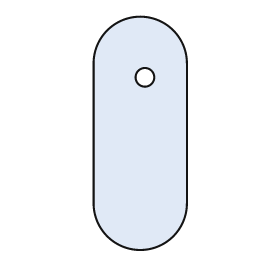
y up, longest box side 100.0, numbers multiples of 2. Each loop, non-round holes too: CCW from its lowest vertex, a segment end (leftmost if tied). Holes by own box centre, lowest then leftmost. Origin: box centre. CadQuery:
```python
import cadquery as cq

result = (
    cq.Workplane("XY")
    .moveTo(-20.0, -30.0)
    .threePointArc((0.0, -50.0), (20.0, -30.0))
    .lineTo(20.0, 30.0)
    .threePointArc((0.0, 50.0), (-20.0, 30.0))
    .close()
    .moveTo(2.0, 24.0)
    .circle(4.0)
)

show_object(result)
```